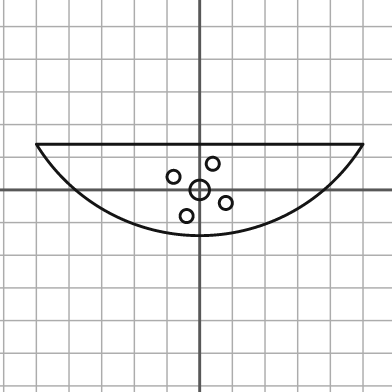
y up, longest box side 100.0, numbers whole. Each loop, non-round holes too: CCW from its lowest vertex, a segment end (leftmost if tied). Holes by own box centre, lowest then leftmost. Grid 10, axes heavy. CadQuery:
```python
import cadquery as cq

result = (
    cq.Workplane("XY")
    .moveTo(-50.0, 14.0)
    .threePointArc((0.0, -14.0), (50.0, 14.0))
    .close()
    .moveTo(-4.0, -8.0)
    .circle(2.0)
    .moveTo(8.0, -4.0)
    .circle(2.0)
    .moveTo(0.0, 0.0)
    .circle(3.0)
    .moveTo(-8.0, 4.0)
    .circle(2.0)
    .moveTo(4.0, 8.0)
    .circle(2.0)
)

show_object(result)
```